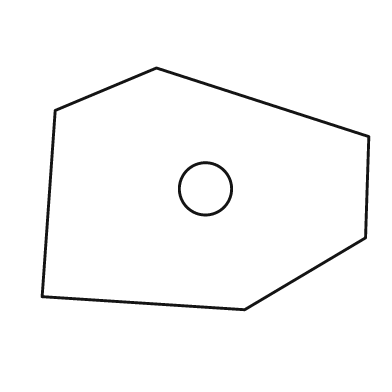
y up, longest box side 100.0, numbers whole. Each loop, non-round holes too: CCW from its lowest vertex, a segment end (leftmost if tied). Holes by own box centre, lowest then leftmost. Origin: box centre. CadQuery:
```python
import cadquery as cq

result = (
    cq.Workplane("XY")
    .moveTo(12.0, -37.0)
    .lineTo(49.0, -15.0)
    .lineTo(50.0, 16.0)
    .lineTo(-15.0, 37.0)
    .lineTo(-46.0, 24.0)
    .lineTo(-50.0, -33.0)
    .close()
    .moveTo(0.0, 0.0)
    .circle(8.0)
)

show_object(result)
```